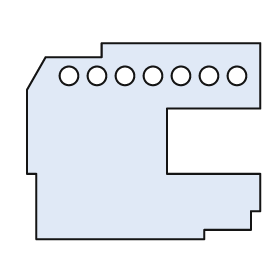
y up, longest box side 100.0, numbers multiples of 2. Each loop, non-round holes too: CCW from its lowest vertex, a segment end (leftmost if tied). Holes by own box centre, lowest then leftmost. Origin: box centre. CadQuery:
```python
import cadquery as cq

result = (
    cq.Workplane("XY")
    .moveTo(-46.0, -42.0)
    .lineTo(26.0, -42.0)
    .lineTo(26.0, -38.0)
    .lineTo(46.0, -38.0)
    .lineTo(46.0, -30.0)
    .lineTo(50.0, -30.0)
    .lineTo(50.0, -14.0)
    .lineTo(10.0, -14.0)
    .lineTo(10.0, 14.0)
    .lineTo(50.0, 14.0)
    .lineTo(50.0, 42.0)
    .lineTo(-18.0, 42.0)
    .lineTo(-18.0, 36.0)
    .lineTo(-42.0, 36.0)
    .lineTo(-50.0, 22.0)
    .lineTo(-50.0, -14.0)
    .lineTo(-46.0, -14.0)
    .close()
    .moveTo(-32.0, 28.0)
    .circle(4.0)
    .moveTo(-20.0, 28.0)
    .circle(4.0)
    .moveTo(-8.0, 28.0)
    .circle(4.0)
    .moveTo(4.0, 28.0)
    .circle(4.0)
    .moveTo(16.0, 28.0)
    .circle(4.0)
    .moveTo(28.0, 28.0)
    .circle(4.0)
    .moveTo(40.0, 28.0)
    .circle(4.0)
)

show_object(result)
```